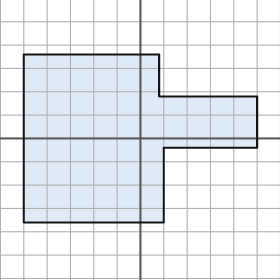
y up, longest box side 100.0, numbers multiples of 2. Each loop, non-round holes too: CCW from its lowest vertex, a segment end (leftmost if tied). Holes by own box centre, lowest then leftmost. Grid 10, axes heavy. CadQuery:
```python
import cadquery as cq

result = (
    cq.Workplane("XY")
    .moveTo(-50.0, -36.0)
    .lineTo(10.0, -36.0)
    .lineTo(10.0, -4.0)
    .lineTo(50.0, -4.0)
    .lineTo(50.0, 18.0)
    .lineTo(8.0, 18.0)
    .lineTo(8.0, 36.0)
    .lineTo(-50.0, 36.0)
    .close()
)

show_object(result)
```